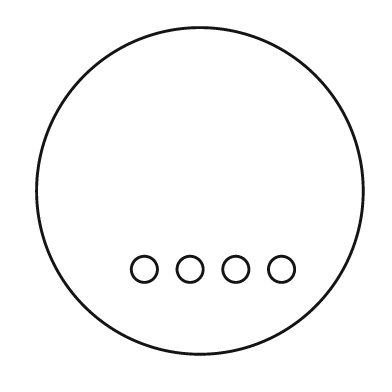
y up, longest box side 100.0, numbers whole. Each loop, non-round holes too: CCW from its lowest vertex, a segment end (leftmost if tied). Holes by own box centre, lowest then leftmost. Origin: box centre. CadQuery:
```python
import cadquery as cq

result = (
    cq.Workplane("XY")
    .moveTo(0.0, 0.0)
    .circle(50.0)
    .moveTo(-17.0, -24.0)
    .circle(4.0)
    .moveTo(-3.0, -24.0)
    .circle(4.0)
    .moveTo(11.0, -24.0)
    .circle(4.0)
    .moveTo(25.0, -24.0)
    .circle(4.0)
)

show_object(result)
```